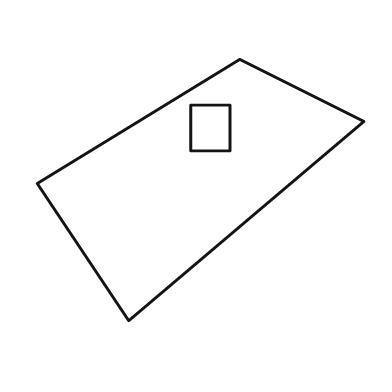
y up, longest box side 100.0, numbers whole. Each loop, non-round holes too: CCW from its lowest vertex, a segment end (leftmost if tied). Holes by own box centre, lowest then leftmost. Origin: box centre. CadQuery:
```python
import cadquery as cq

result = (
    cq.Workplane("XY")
    .moveTo(-22.0, -40.0)
    .lineTo(50.0, 21.0)
    .lineTo(12.0, 40.0)
    .lineTo(-50.0, 2.0)
    .close()
    .moveTo(-3.0, 12.0)
    .lineTo(9.0, 12.0)
    .lineTo(9.0, 26.0)
    .lineTo(-3.0, 26.0)
    .close()
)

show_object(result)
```